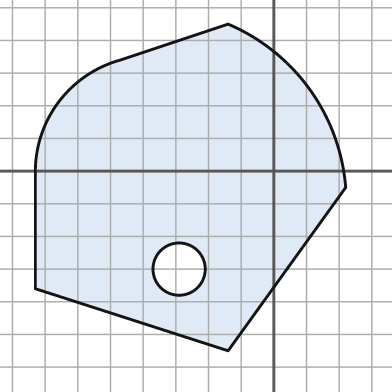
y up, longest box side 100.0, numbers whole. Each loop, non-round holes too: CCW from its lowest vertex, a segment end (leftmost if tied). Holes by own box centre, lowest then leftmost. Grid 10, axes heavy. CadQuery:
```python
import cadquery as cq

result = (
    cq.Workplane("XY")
    .moveTo(-14.0, -55.0)
    .lineTo(22.0, -5.0)
    .threePointArc((11.0, 25.0), (-14.0, 45.0))
    .lineTo(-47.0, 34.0)
    .threePointArc((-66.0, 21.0), (-73.0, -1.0))
    .lineTo(-73.0, -36.0)
    .close()
    .moveTo(-29.0, -30.0)
    .circle(8.0)
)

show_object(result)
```